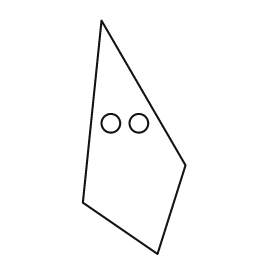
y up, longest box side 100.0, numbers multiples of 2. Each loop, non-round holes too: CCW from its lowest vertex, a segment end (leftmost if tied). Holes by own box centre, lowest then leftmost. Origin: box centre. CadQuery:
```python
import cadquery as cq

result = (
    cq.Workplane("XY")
    .moveTo(10.0, -50.0)
    .lineTo(22.0, -12.0)
    .lineTo(-14.0, 50.0)
    .lineTo(-22.0, -28.0)
    .close()
    .moveTo(-10.0, 6.0)
    .circle(4.0)
    .moveTo(2.0, 6.0)
    .circle(4.0)
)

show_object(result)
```